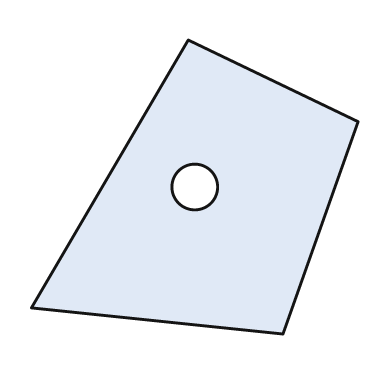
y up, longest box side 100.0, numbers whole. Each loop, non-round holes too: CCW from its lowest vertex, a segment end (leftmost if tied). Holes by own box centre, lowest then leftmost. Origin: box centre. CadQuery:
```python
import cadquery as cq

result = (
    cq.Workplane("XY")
    .moveTo(27.0, -45.0)
    .lineTo(50.0, 20.0)
    .lineTo(-2.0, 45.0)
    .lineTo(-50.0, -37.0)
    .close()
    .moveTo(0.0, 0.0)
    .circle(7.0)
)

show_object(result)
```